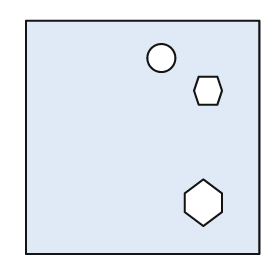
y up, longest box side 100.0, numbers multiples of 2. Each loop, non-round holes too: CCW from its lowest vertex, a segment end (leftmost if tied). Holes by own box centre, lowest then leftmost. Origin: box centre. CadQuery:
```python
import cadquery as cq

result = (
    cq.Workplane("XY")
    .moveTo(-50.0, -50.0)
    .lineTo(50.0, -50.0)
    .lineTo(50.0, 50.0)
    .lineTo(-50.0, 50.0)
    .close()
    .moveTo(26.0, -38.0)
    .lineTo(34.0, -32.0)
    .lineTo(34.0, -24.0)
    .lineTo(26.0, -18.0)
    .lineTo(18.0, -24.0)
    .lineTo(18.0, -32.0)
    .close()
    .moveTo(24.0, 14.0)
    .lineTo(32.0, 14.0)
    .lineTo(34.0, 20.0)
    .lineTo(32.0, 26.0)
    .lineTo(24.0, 26.0)
    .lineTo(22.0, 20.0)
    .close()
    .moveTo(8.0, 34.0)
    .circle(6.0)
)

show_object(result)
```